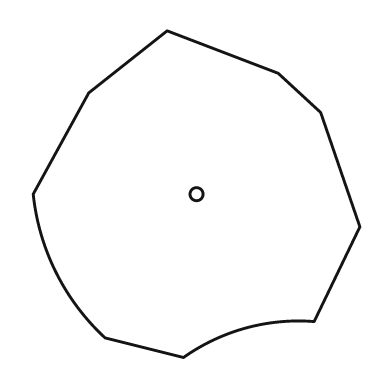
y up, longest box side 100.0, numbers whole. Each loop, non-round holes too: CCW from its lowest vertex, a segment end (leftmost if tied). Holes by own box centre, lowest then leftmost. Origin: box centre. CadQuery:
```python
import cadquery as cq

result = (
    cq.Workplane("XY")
    .moveTo(-4.0, -50.0)
    .threePointArc((15.0, -41.0), (36.0, -39.0))
    .lineTo(50.0, -10.0)
    .lineTo(38.0, 25.0)
    .lineTo(25.0, 37.0)
    .lineTo(-9.0, 50.0)
    .lineTo(-33.0, 31.0)
    .lineTo(-50.0, 0.0)
    .threePointArc((-43.0, -24.0), (-28.0, -44.0))
    .close()
    .moveTo(0.0, 0.0)
    .circle(2.0)
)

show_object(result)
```